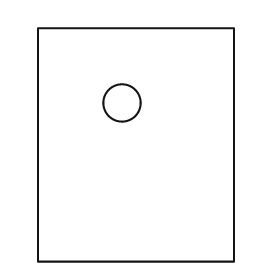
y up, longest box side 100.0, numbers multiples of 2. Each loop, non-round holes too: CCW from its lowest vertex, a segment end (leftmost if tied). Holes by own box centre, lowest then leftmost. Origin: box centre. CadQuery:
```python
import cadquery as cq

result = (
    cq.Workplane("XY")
    .moveTo(-42.0, -50.0)
    .lineTo(42.0, -50.0)
    .lineTo(42.0, 50.0)
    .lineTo(-42.0, 50.0)
    .close()
    .moveTo(-6.0, 18.0)
    .circle(8.0)
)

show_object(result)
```